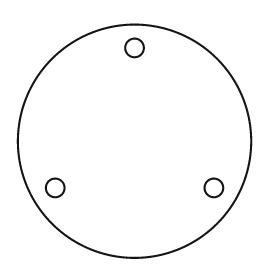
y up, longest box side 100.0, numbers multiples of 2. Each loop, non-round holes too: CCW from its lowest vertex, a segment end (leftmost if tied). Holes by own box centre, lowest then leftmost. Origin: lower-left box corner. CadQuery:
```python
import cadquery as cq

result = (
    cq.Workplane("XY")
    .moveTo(50.0, 50.0)
    .circle(50.0)
    .moveTo(16.0, 30.0)
    .circle(4.0)
    .moveTo(84.0, 30.0)
    .circle(4.0)
    .moveTo(50.0, 90.0)
    .circle(4.0)
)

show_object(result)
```